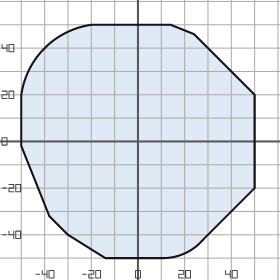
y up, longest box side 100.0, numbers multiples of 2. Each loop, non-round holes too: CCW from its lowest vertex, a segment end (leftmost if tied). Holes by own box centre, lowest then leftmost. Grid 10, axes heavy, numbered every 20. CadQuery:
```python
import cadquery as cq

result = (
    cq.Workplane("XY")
    .moveTo(-14.0, -50.0)
    .lineTo(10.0, -50.0)
    .threePointArc((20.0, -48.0), (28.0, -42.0))
    .lineTo(50.0, -20.0)
    .lineTo(50.0, 20.0)
    .lineTo(24.0, 46.0)
    .lineTo(14.0, 50.0)
    .lineTo(-20.0, 50.0)
    .threePointArc((-40.0, 40.0), (-50.0, 20.0))
    .lineTo(-50.0, -2.0)
    .lineTo(-38.0, -32.0)
    .lineTo(-30.0, -40.0)
    .close()
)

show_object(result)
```